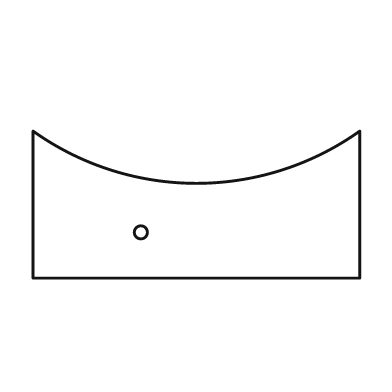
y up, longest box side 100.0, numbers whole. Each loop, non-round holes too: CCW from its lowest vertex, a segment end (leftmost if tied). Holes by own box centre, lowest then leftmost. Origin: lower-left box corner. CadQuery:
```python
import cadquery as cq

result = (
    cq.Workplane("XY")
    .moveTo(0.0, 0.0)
    .lineTo(100.0, 0.0)
    .lineTo(100.0, 45.0)
    .threePointArc((50.0, 29.0), (0.0, 45.0))
    .close()
    .moveTo(33.0, 14.0)
    .circle(2.0)
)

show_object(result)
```